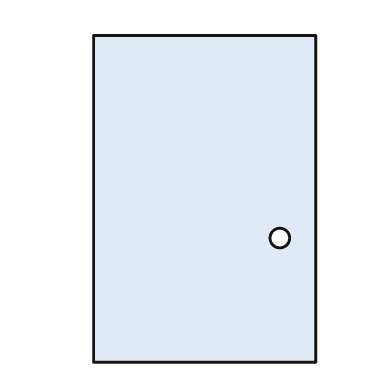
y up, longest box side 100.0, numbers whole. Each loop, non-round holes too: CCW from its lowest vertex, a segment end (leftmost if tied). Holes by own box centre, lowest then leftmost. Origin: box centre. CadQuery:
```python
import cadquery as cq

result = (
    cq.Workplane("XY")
    .moveTo(-34.0, -50.0)
    .lineTo(34.0, -50.0)
    .lineTo(34.0, 50.0)
    .lineTo(-34.0, 50.0)
    .close()
    .moveTo(23.0, -12.0)
    .circle(3.0)
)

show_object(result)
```